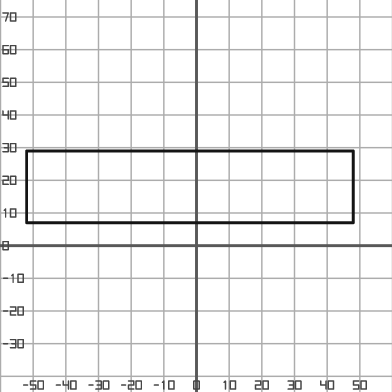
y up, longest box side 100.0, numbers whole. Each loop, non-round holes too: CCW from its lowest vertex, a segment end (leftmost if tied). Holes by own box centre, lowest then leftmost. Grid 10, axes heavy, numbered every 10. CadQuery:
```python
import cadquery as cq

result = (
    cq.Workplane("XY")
    .moveTo(-52.0, 7.0)
    .lineTo(48.0, 7.0)
    .lineTo(48.0, 29.0)
    .lineTo(-52.0, 29.0)
    .close()
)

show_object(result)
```